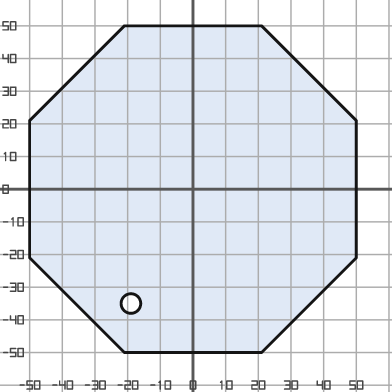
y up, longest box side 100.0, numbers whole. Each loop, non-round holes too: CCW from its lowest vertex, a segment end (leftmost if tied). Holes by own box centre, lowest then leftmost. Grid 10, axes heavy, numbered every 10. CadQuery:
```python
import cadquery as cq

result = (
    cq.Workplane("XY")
    .moveTo(-21.0, -50.0)
    .lineTo(21.0, -50.0)
    .lineTo(50.0, -21.0)
    .lineTo(50.0, 21.0)
    .lineTo(21.0, 50.0)
    .lineTo(-21.0, 50.0)
    .lineTo(-50.0, 21.0)
    .lineTo(-50.0, -21.0)
    .close()
    .moveTo(-19.0, -35.0)
    .circle(3.0)
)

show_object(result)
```